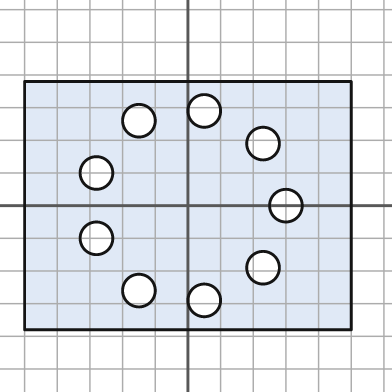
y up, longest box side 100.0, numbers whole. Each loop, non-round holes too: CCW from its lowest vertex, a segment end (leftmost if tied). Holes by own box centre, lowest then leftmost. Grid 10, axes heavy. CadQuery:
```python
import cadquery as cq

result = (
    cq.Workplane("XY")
    .moveTo(-50.0, -38.0)
    .lineTo(50.0, -38.0)
    .lineTo(50.0, 38.0)
    .lineTo(-50.0, 38.0)
    .close()
    .moveTo(5.0, -29.0)
    .circle(5.0)
    .moveTo(-15.0, -26.0)
    .circle(5.0)
    .moveTo(23.0, -19.0)
    .circle(5.0)
    .moveTo(-28.0, -10.0)
    .circle(5.0)
    .moveTo(30.0, 0.0)
    .circle(5.0)
    .moveTo(-28.0, 10.0)
    .circle(5.0)
    .moveTo(23.0, 19.0)
    .circle(5.0)
    .moveTo(-15.0, 26.0)
    .circle(5.0)
    .moveTo(5.0, 29.0)
    .circle(5.0)
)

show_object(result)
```